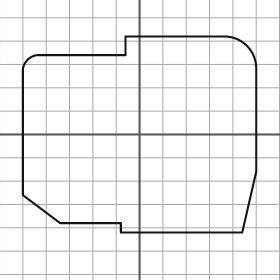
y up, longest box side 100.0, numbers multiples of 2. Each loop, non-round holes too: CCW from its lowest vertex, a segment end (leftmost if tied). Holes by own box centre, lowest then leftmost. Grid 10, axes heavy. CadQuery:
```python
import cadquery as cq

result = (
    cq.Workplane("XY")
    .moveTo(-8.0, -42.0)
    .lineTo(44.0, -42.0)
    .lineTo(50.0, -16.0)
    .lineTo(50.0, 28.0)
    .threePointArc((46.0, 38.0), (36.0, 42.0))
    .lineTo(-6.0, 42.0)
    .lineTo(-6.0, 34.0)
    .lineTo(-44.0, 34.0)
    .threePointArc((-48.0, 32.0), (-50.0, 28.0))
    .lineTo(-50.0, -26.0)
    .lineTo(-34.0, -38.0)
    .lineTo(-8.0, -38.0)
    .close()
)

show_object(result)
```